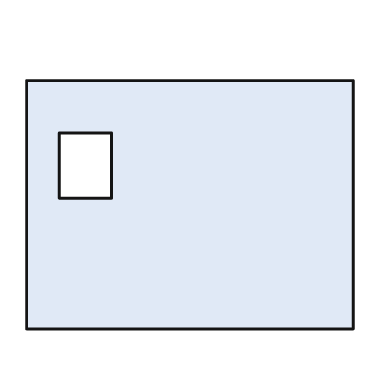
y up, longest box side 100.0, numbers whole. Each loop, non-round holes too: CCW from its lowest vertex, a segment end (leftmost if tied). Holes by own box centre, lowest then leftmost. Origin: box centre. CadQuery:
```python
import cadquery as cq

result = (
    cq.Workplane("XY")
    .moveTo(-50.0, -38.0)
    .lineTo(50.0, -38.0)
    .lineTo(50.0, 38.0)
    .lineTo(-50.0, 38.0)
    .close()
    .moveTo(-40.0, 2.0)
    .lineTo(-24.0, 2.0)
    .lineTo(-24.0, 22.0)
    .lineTo(-40.0, 22.0)
    .close()
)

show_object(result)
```